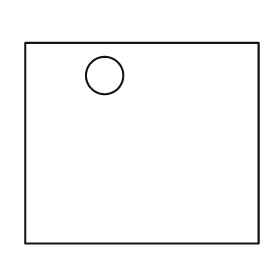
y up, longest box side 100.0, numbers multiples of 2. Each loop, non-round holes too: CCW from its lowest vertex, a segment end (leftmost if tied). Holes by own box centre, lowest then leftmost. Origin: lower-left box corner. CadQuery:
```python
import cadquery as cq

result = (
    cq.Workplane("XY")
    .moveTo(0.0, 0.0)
    .lineTo(100.0, 0.0)
    .lineTo(100.0, 86.0)
    .lineTo(0.0, 86.0)
    .close()
    .moveTo(34.0, 72.0)
    .circle(8.0)
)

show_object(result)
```